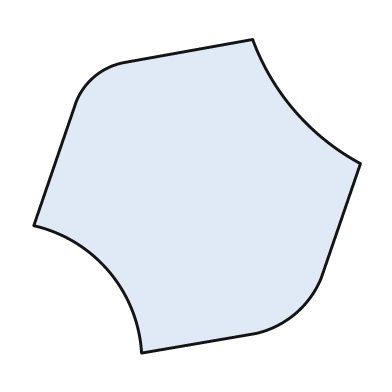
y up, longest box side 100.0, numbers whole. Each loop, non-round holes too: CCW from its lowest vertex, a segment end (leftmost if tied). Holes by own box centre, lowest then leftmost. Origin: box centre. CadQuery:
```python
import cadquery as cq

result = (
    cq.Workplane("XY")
    .moveTo(-17.0, -48.0)
    .lineTo(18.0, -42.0)
    .threePointArc((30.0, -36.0), (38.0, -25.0))
    .lineTo(50.0, 10.0)
    .threePointArc((30.0, 26.0), (17.0, 48.0))
    .lineTo(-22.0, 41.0)
    .threePointArc((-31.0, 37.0), (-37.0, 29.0))
    .lineTo(-50.0, -9.0)
    .threePointArc((-27.0, -23.0), (-17.0, -48.0))
    .close()
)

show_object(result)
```